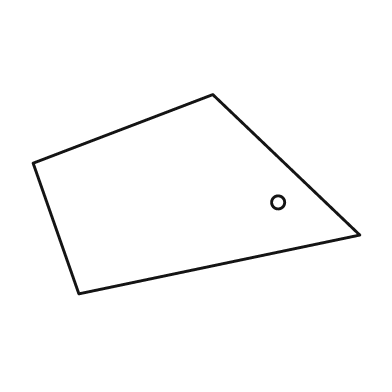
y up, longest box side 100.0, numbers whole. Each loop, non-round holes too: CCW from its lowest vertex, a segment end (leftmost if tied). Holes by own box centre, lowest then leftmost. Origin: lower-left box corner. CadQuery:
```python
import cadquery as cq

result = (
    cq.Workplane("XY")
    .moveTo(14.0, 0.0)
    .lineTo(100.0, 18.0)
    .lineTo(55.0, 61.0)
    .lineTo(0.0, 40.0)
    .close()
    .moveTo(75.0, 28.0)
    .circle(2.0)
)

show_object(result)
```